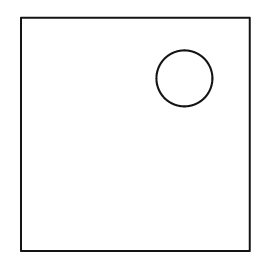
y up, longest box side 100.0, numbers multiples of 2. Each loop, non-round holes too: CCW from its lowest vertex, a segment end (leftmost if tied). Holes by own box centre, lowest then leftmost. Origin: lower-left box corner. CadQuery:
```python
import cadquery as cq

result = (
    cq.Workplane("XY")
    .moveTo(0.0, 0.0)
    .lineTo(98.0, 0.0)
    .lineTo(98.0, 100.0)
    .lineTo(0.0, 100.0)
    .close()
    .moveTo(70.0, 74.0)
    .circle(12.0)
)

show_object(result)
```